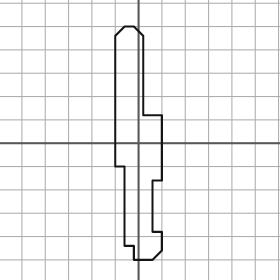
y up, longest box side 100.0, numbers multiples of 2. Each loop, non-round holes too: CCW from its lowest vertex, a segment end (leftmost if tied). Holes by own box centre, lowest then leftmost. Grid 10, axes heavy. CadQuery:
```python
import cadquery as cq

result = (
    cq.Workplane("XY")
    .moveTo(-2.0, -50.0)
    .lineTo(6.0, -50.0)
    .lineTo(10.0, -46.0)
    .lineTo(10.0, -38.0)
    .lineTo(6.0, -38.0)
    .lineTo(6.0, -16.0)
    .lineTo(10.0, -16.0)
    .lineTo(10.0, 12.0)
    .lineTo(2.0, 12.0)
    .lineTo(2.0, 46.0)
    .lineTo(-2.0, 50.0)
    .lineTo(-6.0, 50.0)
    .lineTo(-10.0, 46.0)
    .lineTo(-10.0, -10.0)
    .lineTo(-6.0, -10.0)
    .lineTo(-6.0, -44.0)
    .lineTo(-2.0, -44.0)
    .close()
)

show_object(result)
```